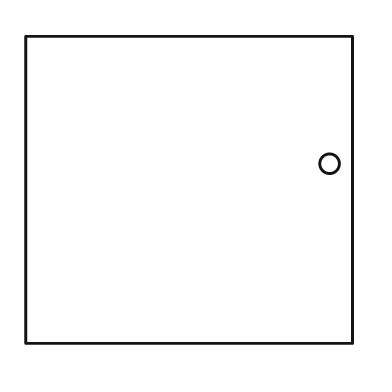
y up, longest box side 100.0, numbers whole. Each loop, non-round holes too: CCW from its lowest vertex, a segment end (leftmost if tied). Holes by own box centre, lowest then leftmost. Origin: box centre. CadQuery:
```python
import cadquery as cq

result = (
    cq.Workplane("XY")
    .moveTo(-50.0, -47.0)
    .lineTo(50.0, -47.0)
    .lineTo(50.0, 47.0)
    .lineTo(-50.0, 47.0)
    .close()
    .moveTo(43.0, 8.0)
    .circle(3.0)
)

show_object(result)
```